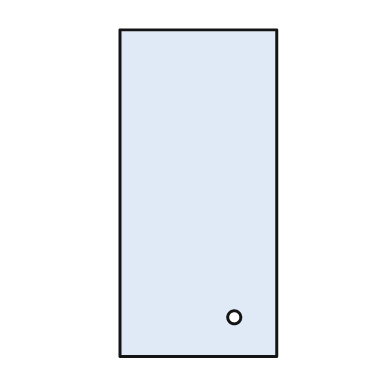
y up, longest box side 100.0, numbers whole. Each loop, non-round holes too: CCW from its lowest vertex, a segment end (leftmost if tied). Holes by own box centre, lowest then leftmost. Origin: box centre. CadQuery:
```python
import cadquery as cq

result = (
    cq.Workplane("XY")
    .moveTo(-24.0, -50.0)
    .lineTo(24.0, -50.0)
    .lineTo(24.0, 50.0)
    .lineTo(-24.0, 50.0)
    .close()
    .moveTo(11.0, -38.0)
    .circle(2.0)
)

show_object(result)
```